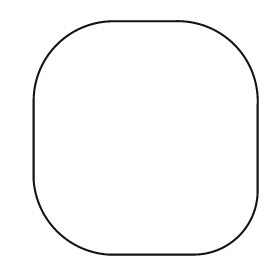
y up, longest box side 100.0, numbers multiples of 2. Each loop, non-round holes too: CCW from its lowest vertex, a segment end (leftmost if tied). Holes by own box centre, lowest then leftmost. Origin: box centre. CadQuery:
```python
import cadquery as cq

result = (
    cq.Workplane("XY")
    .moveTo(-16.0, -50.0)
    .lineTo(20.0, -50.0)
    .threePointArc((40.0, -42.0), (48.0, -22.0))
    .lineTo(48.0, 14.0)
    .threePointArc((38.0, 40.0), (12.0, 50.0))
    .lineTo(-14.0, 50.0)
    .threePointArc((-38.0, 40.0), (-48.0, 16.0))
    .lineTo(-48.0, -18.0)
    .threePointArc((-38.0, -40.0), (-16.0, -50.0))
    .close()
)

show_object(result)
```